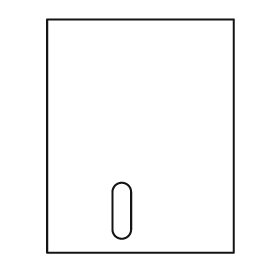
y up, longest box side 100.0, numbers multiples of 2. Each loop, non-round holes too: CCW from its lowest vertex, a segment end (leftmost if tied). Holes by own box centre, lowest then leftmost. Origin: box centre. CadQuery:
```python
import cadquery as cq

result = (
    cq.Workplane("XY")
    .moveTo(-40.0, -50.0)
    .lineTo(40.0, -50.0)
    .lineTo(40.0, 50.0)
    .lineTo(-40.0, 50.0)
    .close()
    .moveTo(-12.0, -40.0)
    .threePointArc((-8.0, -44.0), (-4.0, -40.0))
    .lineTo(-4.0, -24.0)
    .threePointArc((-8.0, -20.0), (-12.0, -24.0))
    .close()
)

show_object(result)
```